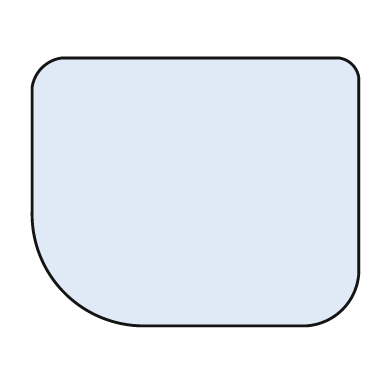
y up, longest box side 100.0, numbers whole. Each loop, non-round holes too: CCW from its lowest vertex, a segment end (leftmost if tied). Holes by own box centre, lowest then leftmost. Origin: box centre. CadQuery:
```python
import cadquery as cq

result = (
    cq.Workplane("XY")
    .moveTo(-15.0, -41.0)
    .lineTo(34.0, -41.0)
    .threePointArc((45.0, -36.0), (50.0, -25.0))
    .lineTo(50.0, 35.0)
    .threePointArc((48.0, 39.0), (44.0, 41.0))
    .lineTo(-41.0, 41.0)
    .threePointArc((-47.0, 38.0), (-50.0, 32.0))
    .lineTo(-50.0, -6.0)
    .threePointArc((-40.0, -31.0), (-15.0, -41.0))
    .close()
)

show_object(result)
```